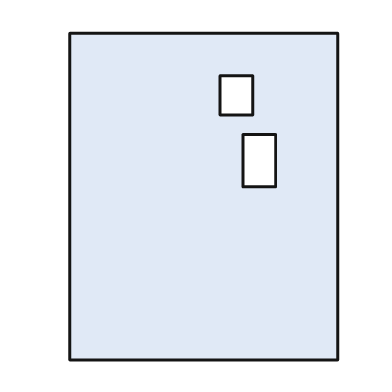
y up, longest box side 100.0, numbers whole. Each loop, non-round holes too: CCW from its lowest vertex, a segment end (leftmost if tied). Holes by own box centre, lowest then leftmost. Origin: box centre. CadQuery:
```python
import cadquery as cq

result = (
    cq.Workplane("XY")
    .moveTo(-41.0, -50.0)
    .lineTo(41.0, -50.0)
    .lineTo(41.0, 50.0)
    .lineTo(-41.0, 50.0)
    .close()
    .moveTo(12.0, 3.0)
    .lineTo(22.0, 3.0)
    .lineTo(22.0, 19.0)
    .lineTo(12.0, 19.0)
    .close()
    .moveTo(5.0, 25.0)
    .lineTo(15.0, 25.0)
    .lineTo(15.0, 37.0)
    .lineTo(5.0, 37.0)
    .close()
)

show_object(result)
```